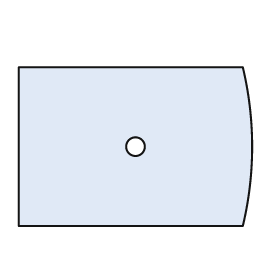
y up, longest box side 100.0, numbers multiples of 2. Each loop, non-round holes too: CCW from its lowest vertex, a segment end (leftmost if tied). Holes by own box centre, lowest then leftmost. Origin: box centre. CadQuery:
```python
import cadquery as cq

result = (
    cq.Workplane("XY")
    .moveTo(-50.0, -34.0)
    .lineTo(46.0, -34.0)
    .threePointArc((50.0, 0.0), (46.0, 34.0))
    .lineTo(-50.0, 34.0)
    .close()
    .moveTo(0.0, 0.0)
    .circle(4.0)
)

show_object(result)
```